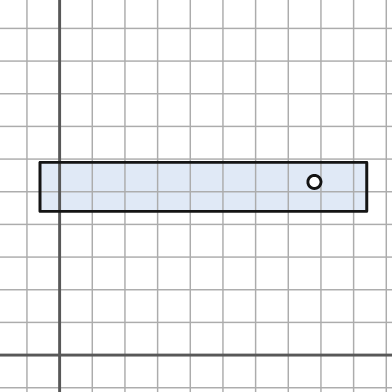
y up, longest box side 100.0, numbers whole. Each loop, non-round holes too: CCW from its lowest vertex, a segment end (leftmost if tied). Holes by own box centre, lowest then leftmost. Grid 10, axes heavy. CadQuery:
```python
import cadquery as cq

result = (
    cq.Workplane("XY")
    .moveTo(-6.0, 44.0)
    .lineTo(94.0, 44.0)
    .lineTo(94.0, 59.0)
    .lineTo(-6.0, 59.0)
    .close()
    .moveTo(78.0, 53.0)
    .circle(2.0)
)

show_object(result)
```